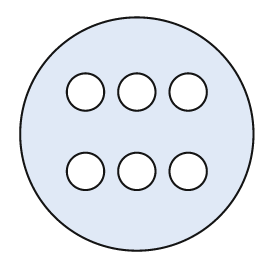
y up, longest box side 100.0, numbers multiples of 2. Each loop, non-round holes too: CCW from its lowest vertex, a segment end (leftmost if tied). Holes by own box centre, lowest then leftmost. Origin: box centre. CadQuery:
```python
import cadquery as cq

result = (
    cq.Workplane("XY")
    .moveTo(0.0, 0.0)
    .circle(50.0)
    .moveTo(-22.0, -16.0)
    .circle(8.0)
    .moveTo(0.0, -16.0)
    .circle(8.0)
    .moveTo(22.0, -16.0)
    .circle(8.0)
    .moveTo(-22.0, 18.0)
    .circle(8.0)
    .moveTo(0.0, 18.0)
    .circle(8.0)
    .moveTo(22.0, 18.0)
    .circle(8.0)
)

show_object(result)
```